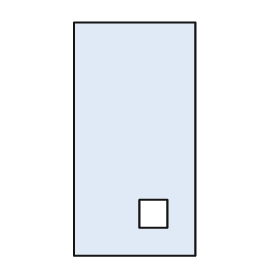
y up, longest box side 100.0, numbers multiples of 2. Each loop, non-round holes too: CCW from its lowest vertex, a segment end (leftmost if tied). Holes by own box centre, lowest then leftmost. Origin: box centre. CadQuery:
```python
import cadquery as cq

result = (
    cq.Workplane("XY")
    .moveTo(-26.0, -50.0)
    .lineTo(26.0, -50.0)
    .lineTo(26.0, 50.0)
    .lineTo(-26.0, 50.0)
    .close()
    .moveTo(2.0, -38.0)
    .lineTo(14.0, -38.0)
    .lineTo(14.0, -26.0)
    .lineTo(2.0, -26.0)
    .close()
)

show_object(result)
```